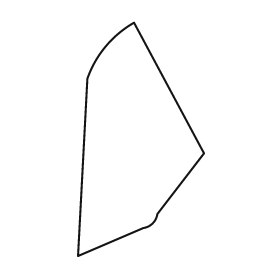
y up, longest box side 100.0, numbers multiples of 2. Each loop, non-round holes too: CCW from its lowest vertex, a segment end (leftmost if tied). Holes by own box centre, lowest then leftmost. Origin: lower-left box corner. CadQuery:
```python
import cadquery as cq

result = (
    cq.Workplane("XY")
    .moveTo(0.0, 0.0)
    .lineTo(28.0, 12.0)
    .threePointArc((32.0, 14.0), (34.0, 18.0))
    .lineTo(54.0, 44.0)
    .lineTo(24.0, 100.0)
    .threePointArc((12.0, 90.0), (4.0, 76.0))
    .close()
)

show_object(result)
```